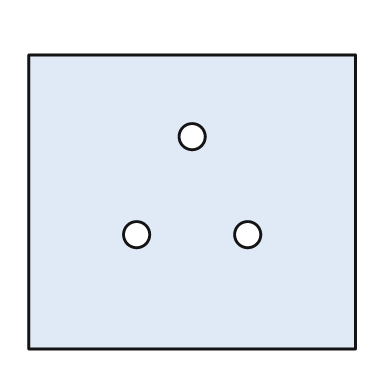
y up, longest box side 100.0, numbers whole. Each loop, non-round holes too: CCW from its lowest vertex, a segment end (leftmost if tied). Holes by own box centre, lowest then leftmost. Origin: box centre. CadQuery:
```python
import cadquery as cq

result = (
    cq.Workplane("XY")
    .moveTo(-50.0, -45.0)
    .lineTo(50.0, -45.0)
    .lineTo(50.0, 45.0)
    .lineTo(-50.0, 45.0)
    .close()
    .moveTo(-17.0, -10.0)
    .circle(4.0)
    .moveTo(17.0, -10.0)
    .circle(4.0)
    .moveTo(0.0, 20.0)
    .circle(4.0)
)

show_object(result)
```